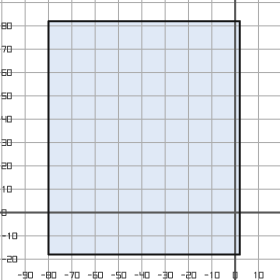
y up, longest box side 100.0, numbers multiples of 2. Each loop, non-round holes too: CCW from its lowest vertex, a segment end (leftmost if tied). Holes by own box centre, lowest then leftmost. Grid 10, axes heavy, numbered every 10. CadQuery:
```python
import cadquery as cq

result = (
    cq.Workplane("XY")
    .moveTo(-80.0, -18.0)
    .lineTo(2.0, -18.0)
    .lineTo(2.0, 82.0)
    .lineTo(-80.0, 82.0)
    .close()
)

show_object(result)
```